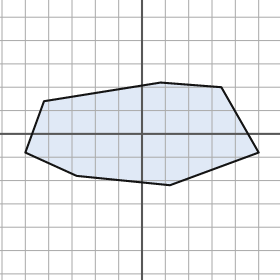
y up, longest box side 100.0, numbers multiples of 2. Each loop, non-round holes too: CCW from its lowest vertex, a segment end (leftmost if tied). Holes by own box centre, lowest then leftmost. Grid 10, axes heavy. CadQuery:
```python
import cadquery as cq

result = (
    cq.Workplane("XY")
    .moveTo(12.0, -22.0)
    .lineTo(50.0, -8.0)
    .lineTo(34.0, 20.0)
    .lineTo(8.0, 22.0)
    .lineTo(-42.0, 14.0)
    .lineTo(-50.0, -8.0)
    .lineTo(-28.0, -18.0)
    .close()
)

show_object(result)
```